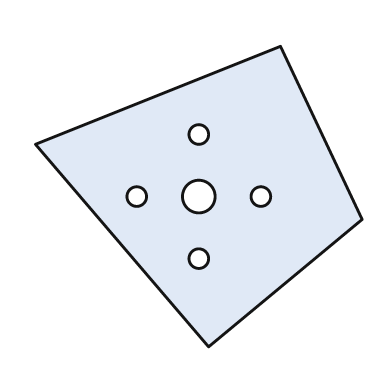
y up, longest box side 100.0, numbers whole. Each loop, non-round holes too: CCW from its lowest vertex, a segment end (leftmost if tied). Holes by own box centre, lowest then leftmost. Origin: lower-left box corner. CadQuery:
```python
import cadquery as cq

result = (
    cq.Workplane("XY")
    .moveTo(53.0, 0.0)
    .lineTo(100.0, 39.0)
    .lineTo(75.0, 92.0)
    .lineTo(0.0, 62.0)
    .close()
    .moveTo(50.0, 27.0)
    .circle(3.0)
    .moveTo(31.0, 46.0)
    .circle(3.0)
    .moveTo(50.0, 46.0)
    .circle(5.0)
    .moveTo(69.0, 46.0)
    .circle(3.0)
    .moveTo(50.0, 65.0)
    .circle(3.0)
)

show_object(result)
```